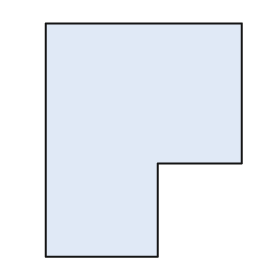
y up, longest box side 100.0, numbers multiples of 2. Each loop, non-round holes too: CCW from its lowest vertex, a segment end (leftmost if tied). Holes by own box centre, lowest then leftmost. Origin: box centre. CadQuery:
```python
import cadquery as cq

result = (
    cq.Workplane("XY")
    .moveTo(-42.0, -50.0)
    .lineTo(6.0, -50.0)
    .lineTo(6.0, -10.0)
    .lineTo(42.0, -10.0)
    .lineTo(42.0, 50.0)
    .lineTo(-42.0, 50.0)
    .close()
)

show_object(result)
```